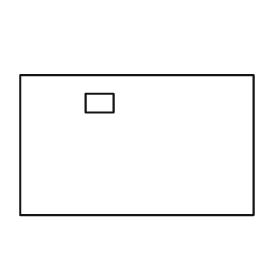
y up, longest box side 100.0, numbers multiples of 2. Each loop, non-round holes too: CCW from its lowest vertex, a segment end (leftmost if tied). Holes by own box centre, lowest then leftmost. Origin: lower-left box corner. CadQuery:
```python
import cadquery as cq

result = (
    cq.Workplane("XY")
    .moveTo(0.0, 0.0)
    .lineTo(100.0, 0.0)
    .lineTo(100.0, 60.0)
    .lineTo(0.0, 60.0)
    .close()
    .moveTo(28.0, 44.0)
    .lineTo(40.0, 44.0)
    .lineTo(40.0, 52.0)
    .lineTo(28.0, 52.0)
    .close()
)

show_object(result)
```